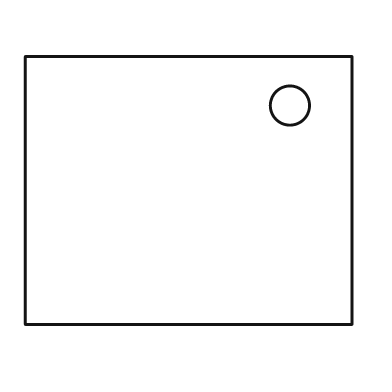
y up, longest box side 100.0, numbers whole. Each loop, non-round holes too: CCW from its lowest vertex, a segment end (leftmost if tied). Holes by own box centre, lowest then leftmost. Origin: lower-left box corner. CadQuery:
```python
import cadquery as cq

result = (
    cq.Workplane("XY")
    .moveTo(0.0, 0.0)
    .lineTo(100.0, 0.0)
    .lineTo(100.0, 82.0)
    .lineTo(0.0, 82.0)
    .close()
    .moveTo(81.0, 67.0)
    .circle(6.0)
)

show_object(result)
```